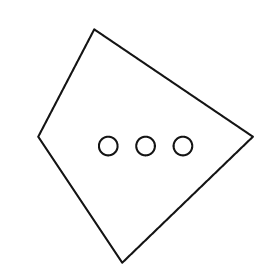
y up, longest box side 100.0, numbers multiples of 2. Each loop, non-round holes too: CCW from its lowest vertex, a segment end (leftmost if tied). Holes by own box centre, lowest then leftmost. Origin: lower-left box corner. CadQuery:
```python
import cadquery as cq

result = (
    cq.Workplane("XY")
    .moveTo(36.0, 0.0)
    .lineTo(92.0, 54.0)
    .lineTo(24.0, 100.0)
    .lineTo(0.0, 54.0)
    .close()
    .moveTo(30.0, 50.0)
    .circle(4.0)
    .moveTo(46.0, 50.0)
    .circle(4.0)
    .moveTo(62.0, 50.0)
    .circle(4.0)
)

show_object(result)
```